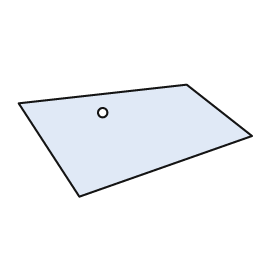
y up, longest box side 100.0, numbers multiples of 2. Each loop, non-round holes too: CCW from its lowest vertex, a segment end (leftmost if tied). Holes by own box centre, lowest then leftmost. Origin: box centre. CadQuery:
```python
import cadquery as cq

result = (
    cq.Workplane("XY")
    .moveTo(-24.0, -24.0)
    .lineTo(50.0, 2.0)
    .lineTo(22.0, 24.0)
    .lineTo(-50.0, 16.0)
    .close()
    .moveTo(-14.0, 12.0)
    .circle(2.0)
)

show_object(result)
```